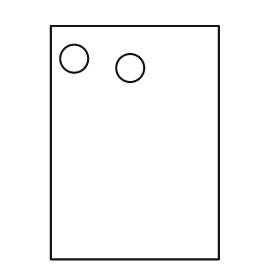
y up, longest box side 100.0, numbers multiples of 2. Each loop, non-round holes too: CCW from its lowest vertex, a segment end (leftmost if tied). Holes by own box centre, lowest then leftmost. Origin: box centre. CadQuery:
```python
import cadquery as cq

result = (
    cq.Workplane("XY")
    .moveTo(-36.0, -50.0)
    .lineTo(36.0, -50.0)
    .lineTo(36.0, 50.0)
    .lineTo(-36.0, 50.0)
    .close()
    .moveTo(-2.0, 32.0)
    .circle(6.0)
    .moveTo(-26.0, 36.0)
    .circle(6.0)
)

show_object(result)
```